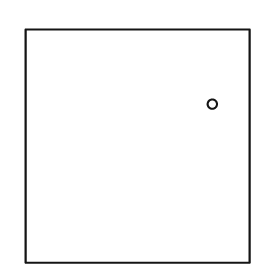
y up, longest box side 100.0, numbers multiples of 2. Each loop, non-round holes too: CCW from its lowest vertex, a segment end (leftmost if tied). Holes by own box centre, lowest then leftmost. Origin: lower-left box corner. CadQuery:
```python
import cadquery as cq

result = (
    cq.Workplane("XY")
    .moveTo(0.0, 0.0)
    .lineTo(96.0, 0.0)
    .lineTo(96.0, 100.0)
    .lineTo(0.0, 100.0)
    .close()
    .moveTo(80.0, 68.0)
    .circle(2.0)
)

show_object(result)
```